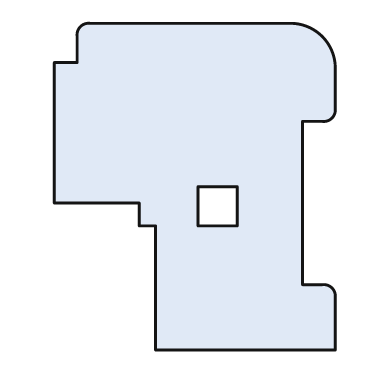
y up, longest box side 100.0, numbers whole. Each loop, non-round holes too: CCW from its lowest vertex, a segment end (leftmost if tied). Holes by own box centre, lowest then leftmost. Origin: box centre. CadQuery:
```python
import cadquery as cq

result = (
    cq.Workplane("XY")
    .moveTo(-12.0, -50.0)
    .lineTo(43.0, -50.0)
    .lineTo(43.0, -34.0)
    .threePointArc((42.0, -31.0), (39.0, -30.0))
    .lineTo(33.0, -30.0)
    .lineTo(33.0, 20.0)
    .lineTo(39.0, 20.0)
    .threePointArc((42.0, 21.0), (43.0, 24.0))
    .lineTo(43.0, 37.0)
    .threePointArc((39.0, 46.0), (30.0, 50.0))
    .lineTo(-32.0, 50.0)
    .threePointArc((-35.0, 49.0), (-36.0, 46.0))
    .lineTo(-36.0, 38.0)
    .lineTo(-43.0, 38.0)
    .lineTo(-43.0, -5.0)
    .lineTo(-17.0, -5.0)
    .lineTo(-17.0, -12.0)
    .lineTo(-12.0, -12.0)
    .close()
    .moveTo(1.0, -12.0)
    .lineTo(13.0, -12.0)
    .lineTo(13.0, 0.0)
    .lineTo(1.0, 0.0)
    .close()
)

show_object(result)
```